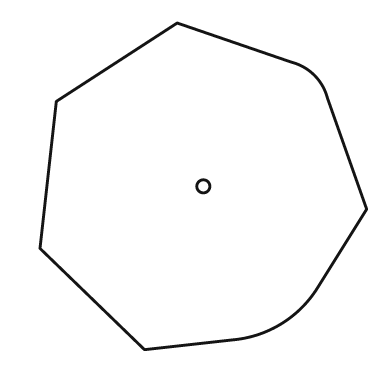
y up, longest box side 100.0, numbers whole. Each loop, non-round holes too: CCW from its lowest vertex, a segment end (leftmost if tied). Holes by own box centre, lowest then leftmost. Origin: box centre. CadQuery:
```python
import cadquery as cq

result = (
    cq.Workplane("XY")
    .moveTo(-18.0, -50.0)
    .lineTo(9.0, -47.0)
    .threePointArc((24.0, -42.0), (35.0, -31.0))
    .lineTo(50.0, -7.0)
    .lineTo(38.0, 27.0)
    .threePointArc((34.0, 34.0), (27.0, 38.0))
    .lineTo(-8.0, 50.0)
    .lineTo(-45.0, 26.0)
    .lineTo(-50.0, -19.0)
    .close()
    .moveTo(0.0, 0.0)
    .circle(2.0)
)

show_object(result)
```